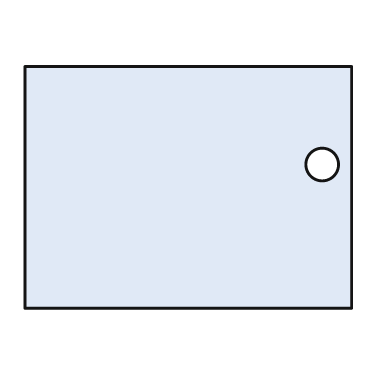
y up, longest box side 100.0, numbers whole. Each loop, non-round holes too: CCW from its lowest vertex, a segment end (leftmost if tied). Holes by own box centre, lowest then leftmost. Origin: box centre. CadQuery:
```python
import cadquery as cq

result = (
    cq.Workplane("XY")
    .moveTo(-50.0, -37.0)
    .lineTo(50.0, -37.0)
    .lineTo(50.0, 37.0)
    .lineTo(-50.0, 37.0)
    .close()
    .moveTo(41.0, 7.0)
    .circle(5.0)
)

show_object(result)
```